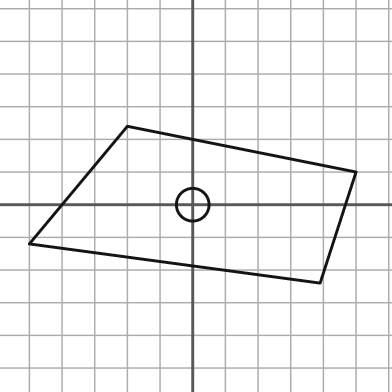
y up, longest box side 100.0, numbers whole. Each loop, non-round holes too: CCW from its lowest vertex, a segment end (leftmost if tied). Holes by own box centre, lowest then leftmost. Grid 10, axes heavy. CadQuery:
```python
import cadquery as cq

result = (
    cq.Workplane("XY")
    .moveTo(39.0, -24.0)
    .lineTo(50.0, 10.0)
    .lineTo(-20.0, 24.0)
    .lineTo(-50.0, -12.0)
    .close()
    .moveTo(0.0, 0.0)
    .circle(5.0)
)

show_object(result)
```